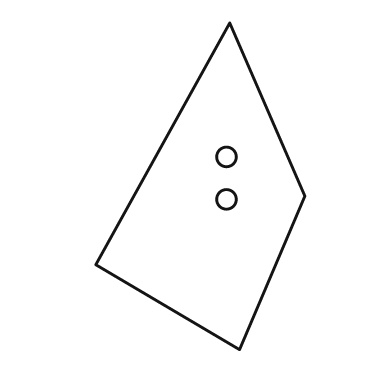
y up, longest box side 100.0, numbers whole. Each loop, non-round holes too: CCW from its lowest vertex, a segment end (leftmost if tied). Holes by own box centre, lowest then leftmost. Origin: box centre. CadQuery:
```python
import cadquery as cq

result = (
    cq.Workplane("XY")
    .moveTo(12.0, -50.0)
    .lineTo(32.0, -3.0)
    .lineTo(9.0, 50.0)
    .lineTo(-32.0, -24.0)
    .close()
    .moveTo(8.0, -4.0)
    .circle(3.0)
    .moveTo(8.0, 9.0)
    .circle(3.0)
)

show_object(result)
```